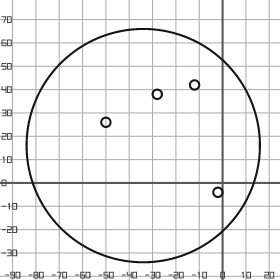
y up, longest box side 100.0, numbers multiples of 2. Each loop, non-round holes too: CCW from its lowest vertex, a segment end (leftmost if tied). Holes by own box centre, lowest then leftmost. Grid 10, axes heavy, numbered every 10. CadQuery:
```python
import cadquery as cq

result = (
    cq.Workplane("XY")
    .moveTo(-34.0, 16.0)
    .circle(50.0)
    .moveTo(-2.0, -4.0)
    .circle(2.0)
    .moveTo(-50.0, 26.0)
    .circle(2.0)
    .moveTo(-28.0, 38.0)
    .circle(2.0)
    .moveTo(-12.0, 42.0)
    .circle(2.0)
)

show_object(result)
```